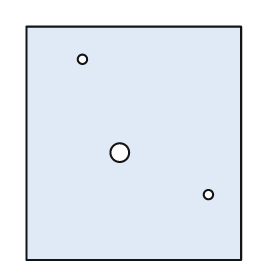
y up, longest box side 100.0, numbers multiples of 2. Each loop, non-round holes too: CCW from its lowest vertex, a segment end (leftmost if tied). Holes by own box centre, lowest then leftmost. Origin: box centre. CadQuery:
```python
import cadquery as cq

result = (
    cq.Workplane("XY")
    .moveTo(-46.0, -50.0)
    .lineTo(46.0, -50.0)
    .lineTo(46.0, 50.0)
    .lineTo(-46.0, 50.0)
    .close()
    .moveTo(32.0, -22.0)
    .circle(2.0)
    .moveTo(-6.0, -4.0)
    .circle(4.0)
    .moveTo(-22.0, 36.0)
    .circle(2.0)
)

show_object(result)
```